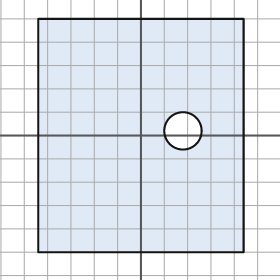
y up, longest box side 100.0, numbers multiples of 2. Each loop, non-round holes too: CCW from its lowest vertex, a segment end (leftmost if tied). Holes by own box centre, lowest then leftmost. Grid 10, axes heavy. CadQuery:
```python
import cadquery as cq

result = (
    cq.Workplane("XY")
    .moveTo(-44.0, -50.0)
    .lineTo(44.0, -50.0)
    .lineTo(44.0, 50.0)
    .lineTo(-44.0, 50.0)
    .close()
    .moveTo(18.0, 2.0)
    .circle(8.0)
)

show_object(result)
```